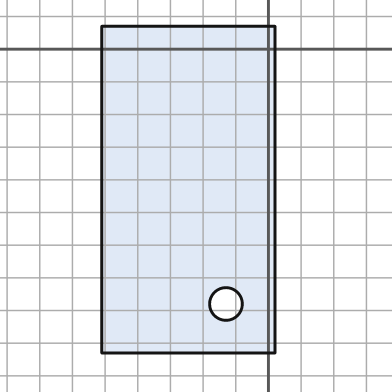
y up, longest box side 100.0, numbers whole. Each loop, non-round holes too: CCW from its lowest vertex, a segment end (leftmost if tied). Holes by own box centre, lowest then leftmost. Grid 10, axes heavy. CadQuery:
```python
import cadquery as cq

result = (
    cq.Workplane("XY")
    .moveTo(-51.0, -93.0)
    .lineTo(2.0, -93.0)
    .lineTo(2.0, 7.0)
    .lineTo(-51.0, 7.0)
    .close()
    .moveTo(-13.0, -78.0)
    .circle(5.0)
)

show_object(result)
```